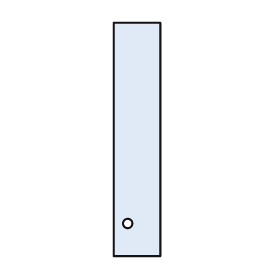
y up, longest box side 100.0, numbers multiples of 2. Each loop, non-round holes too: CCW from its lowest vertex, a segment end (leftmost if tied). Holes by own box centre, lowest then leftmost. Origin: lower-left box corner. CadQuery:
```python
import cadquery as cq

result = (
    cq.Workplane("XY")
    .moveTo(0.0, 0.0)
    .lineTo(20.0, 0.0)
    .lineTo(20.0, 100.0)
    .lineTo(0.0, 100.0)
    .close()
    .moveTo(6.0, 14.0)
    .circle(2.0)
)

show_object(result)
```